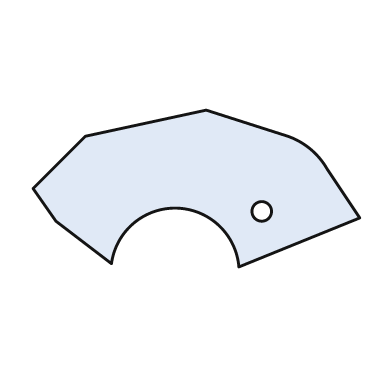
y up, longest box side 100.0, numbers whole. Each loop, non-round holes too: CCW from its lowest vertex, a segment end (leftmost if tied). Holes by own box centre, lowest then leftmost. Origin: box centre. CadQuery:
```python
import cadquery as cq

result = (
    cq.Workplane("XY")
    .moveTo(13.0, -24.0)
    .lineTo(50.0, -9.0)
    .lineTo(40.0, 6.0)
    .threePointArc((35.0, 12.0), (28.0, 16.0))
    .lineTo(3.0, 24.0)
    .lineTo(-34.0, 16.0)
    .lineTo(-50.0, 0.0)
    .lineTo(-43.0, -10.0)
    .lineTo(-26.0, -23.0)
    .threePointArc((-6.0, -6.0), (13.0, -24.0))
    .close()
    .moveTo(20.0, -7.0)
    .circle(3.0)
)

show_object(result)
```